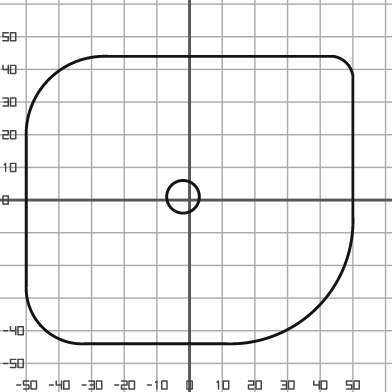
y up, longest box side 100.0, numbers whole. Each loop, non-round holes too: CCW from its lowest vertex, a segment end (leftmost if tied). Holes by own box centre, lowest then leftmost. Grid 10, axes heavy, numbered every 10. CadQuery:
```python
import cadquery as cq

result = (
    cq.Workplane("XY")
    .moveTo(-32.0, -44.0)
    .lineTo(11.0, -44.0)
    .threePointArc((39.0, -33.0), (50.0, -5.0))
    .lineTo(50.0, 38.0)
    .threePointArc((48.0, 42.0), (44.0, 44.0))
    .lineTo(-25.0, 44.0)
    .threePointArc((-43.0, 37.0), (-50.0, 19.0))
    .lineTo(-50.0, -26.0)
    .threePointArc((-45.0, -39.0), (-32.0, -44.0))
    .close()
    .moveTo(-2.0, 1.0)
    .circle(5.0)
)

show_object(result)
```